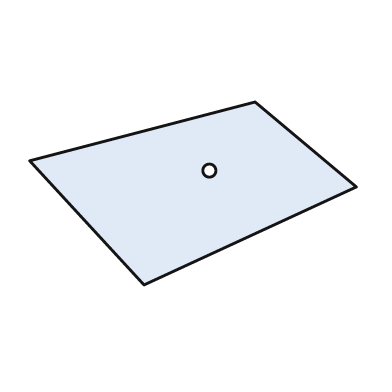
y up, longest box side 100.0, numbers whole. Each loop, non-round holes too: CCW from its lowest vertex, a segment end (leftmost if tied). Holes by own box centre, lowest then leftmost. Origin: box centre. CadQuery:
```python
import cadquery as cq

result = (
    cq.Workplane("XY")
    .moveTo(-15.0, -28.0)
    .lineTo(50.0, 2.0)
    .lineTo(19.0, 28.0)
    .lineTo(-50.0, 10.0)
    .close()
    .moveTo(5.0, 7.0)
    .circle(2.0)
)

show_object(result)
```